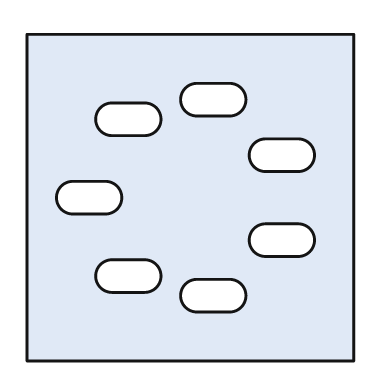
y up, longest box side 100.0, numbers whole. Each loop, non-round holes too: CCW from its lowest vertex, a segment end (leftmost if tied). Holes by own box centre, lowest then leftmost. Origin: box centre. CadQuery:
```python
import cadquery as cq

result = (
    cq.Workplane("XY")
    .moveTo(-50.0, -50.0)
    .lineTo(50.0, -50.0)
    .lineTo(50.0, 50.0)
    .lineTo(-50.0, 50.0)
    .close()
    .moveTo(2.0, -35.0)
    .lineTo(12.0, -35.0)
    .threePointArc((17.0, -30.0), (12.0, -25.0))
    .lineTo(2.0, -25.0)
    .threePointArc((-3.0, -30.0), (2.0, -35.0))
    .close()
    .moveTo(-24.0, -29.0)
    .lineTo(-14.0, -29.0)
    .threePointArc((-9.0, -24.0), (-14.0, -19.0))
    .lineTo(-24.0, -19.0)
    .threePointArc((-29.0, -24.0), (-24.0, -29.0))
    .close()
    .moveTo(23.0, -18.0)
    .lineTo(33.0, -18.0)
    .threePointArc((38.0, -13.0), (33.0, -8.0))
    .lineTo(23.0, -8.0)
    .threePointArc((18.0, -13.0), (23.0, -18.0))
    .close()
    .moveTo(-36.0, -5.0)
    .lineTo(-26.0, -5.0)
    .threePointArc((-21.0, 0.0), (-26.0, 5.0))
    .lineTo(-36.0, 5.0)
    .threePointArc((-41.0, 0.0), (-36.0, -5.0))
    .close()
    .moveTo(23.0, 8.0)
    .lineTo(33.0, 8.0)
    .threePointArc((38.0, 13.0), (33.0, 18.0))
    .lineTo(23.0, 18.0)
    .threePointArc((18.0, 13.0), (23.0, 8.0))
    .close()
    .moveTo(-24.0, 19.0)
    .lineTo(-14.0, 19.0)
    .threePointArc((-9.0, 24.0), (-14.0, 29.0))
    .lineTo(-24.0, 29.0)
    .threePointArc((-29.0, 24.0), (-24.0, 19.0))
    .close()
    .moveTo(2.0, 25.0)
    .lineTo(12.0, 25.0)
    .threePointArc((17.0, 30.0), (12.0, 35.0))
    .lineTo(2.0, 35.0)
    .threePointArc((-3.0, 30.0), (2.0, 25.0))
    .close()
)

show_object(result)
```